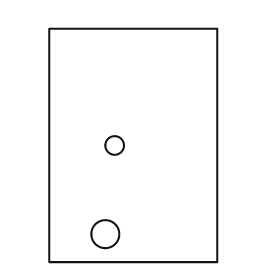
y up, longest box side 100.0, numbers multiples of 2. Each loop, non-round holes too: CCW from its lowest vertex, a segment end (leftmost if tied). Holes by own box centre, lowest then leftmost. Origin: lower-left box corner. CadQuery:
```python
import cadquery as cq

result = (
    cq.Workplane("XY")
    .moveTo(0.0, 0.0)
    .lineTo(72.0, 0.0)
    .lineTo(72.0, 100.0)
    .lineTo(0.0, 100.0)
    .close()
    .moveTo(24.0, 12.0)
    .circle(6.0)
    .moveTo(28.0, 50.0)
    .circle(4.0)
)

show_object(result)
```